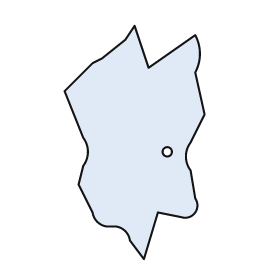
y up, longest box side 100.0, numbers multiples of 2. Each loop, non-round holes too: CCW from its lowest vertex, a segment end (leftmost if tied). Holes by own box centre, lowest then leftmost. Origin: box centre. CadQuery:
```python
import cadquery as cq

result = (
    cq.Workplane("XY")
    .moveTo(4.0, -50.0)
    .lineTo(10.0, -30.0)
    .lineTo(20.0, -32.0)
    .threePointArc((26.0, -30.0), (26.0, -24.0))
    .lineTo(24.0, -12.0)
    .threePointArc((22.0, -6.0), (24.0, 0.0))
    .lineTo(30.0, 12.0)
    .lineTo(26.0, 30.0)
    .threePointArc((28.0, 38.0), (26.0, 46.0))
    .lineTo(6.0, 32.0)
    .lineTo(0.0, 50.0)
    .lineTo(-4.0, 44.0)
    .lineTo(-14.0, 36.0)
    .lineTo(-18.0, 34.0)
    .lineTo(-30.0, 22.0)
    .lineTo(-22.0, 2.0)
    .threePointArc((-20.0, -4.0), (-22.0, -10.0))
    .lineTo(-24.0, -18.0)
    .lineTo(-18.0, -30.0)
    .threePointArc((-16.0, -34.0), (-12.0, -36.0))
    .lineTo(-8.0, -36.0)
    .threePointArc((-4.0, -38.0), (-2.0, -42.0))
    .close()
    .moveTo(14.0, -4.0)
    .circle(2.0)
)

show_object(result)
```